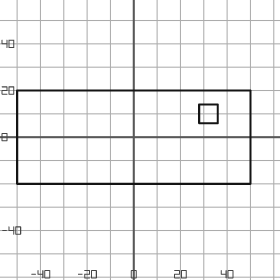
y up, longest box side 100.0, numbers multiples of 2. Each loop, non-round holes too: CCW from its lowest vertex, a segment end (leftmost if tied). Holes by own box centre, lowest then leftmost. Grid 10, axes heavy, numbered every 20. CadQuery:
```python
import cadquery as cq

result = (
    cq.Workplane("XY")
    .moveTo(-50.0, -20.0)
    .lineTo(50.0, -20.0)
    .lineTo(50.0, 20.0)
    .lineTo(-50.0, 20.0)
    .close()
    .moveTo(28.0, 6.0)
    .lineTo(36.0, 6.0)
    .lineTo(36.0, 14.0)
    .lineTo(28.0, 14.0)
    .close()
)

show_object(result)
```